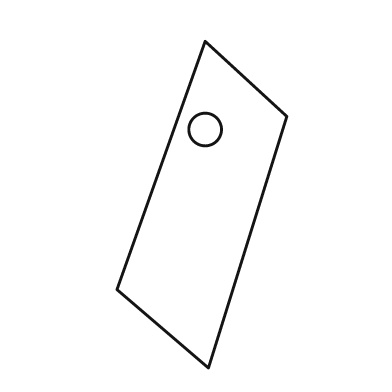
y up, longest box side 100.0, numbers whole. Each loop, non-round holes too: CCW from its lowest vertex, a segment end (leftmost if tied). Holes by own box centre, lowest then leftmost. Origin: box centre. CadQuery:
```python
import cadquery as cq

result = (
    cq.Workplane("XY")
    .moveTo(2.0, -50.0)
    .lineTo(26.0, 27.0)
    .lineTo(1.0, 50.0)
    .lineTo(-26.0, -26.0)
    .close()
    .moveTo(1.0, 23.0)
    .circle(5.0)
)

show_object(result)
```